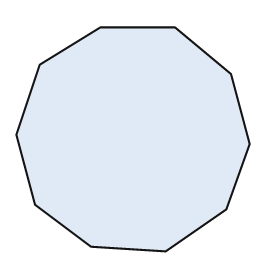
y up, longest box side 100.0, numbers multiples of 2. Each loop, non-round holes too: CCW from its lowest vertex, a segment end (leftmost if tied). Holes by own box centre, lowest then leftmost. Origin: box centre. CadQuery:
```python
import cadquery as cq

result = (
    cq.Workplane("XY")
    .moveTo(14.0, -48.0)
    .lineTo(40.0, -30.0)
    .lineTo(50.0, -2.0)
    .lineTo(42.0, 28.0)
    .lineTo(18.0, 48.0)
    .lineTo(-14.0, 48.0)
    .lineTo(-40.0, 32.0)
    .lineTo(-50.0, 2.0)
    .lineTo(-42.0, -28.0)
    .lineTo(-18.0, -46.0)
    .close()
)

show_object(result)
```